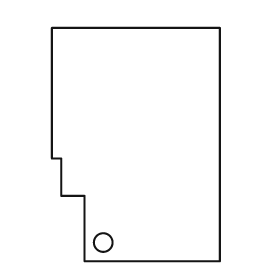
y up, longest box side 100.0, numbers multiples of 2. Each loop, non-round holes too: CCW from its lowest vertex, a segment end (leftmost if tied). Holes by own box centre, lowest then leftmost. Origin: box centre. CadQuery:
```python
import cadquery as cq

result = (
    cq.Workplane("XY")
    .moveTo(-22.0, -50.0)
    .lineTo(36.0, -50.0)
    .lineTo(36.0, 50.0)
    .lineTo(-36.0, 50.0)
    .lineTo(-36.0, -6.0)
    .lineTo(-32.0, -6.0)
    .lineTo(-32.0, -22.0)
    .lineTo(-22.0, -22.0)
    .close()
    .moveTo(-14.0, -42.0)
    .circle(4.0)
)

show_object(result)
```